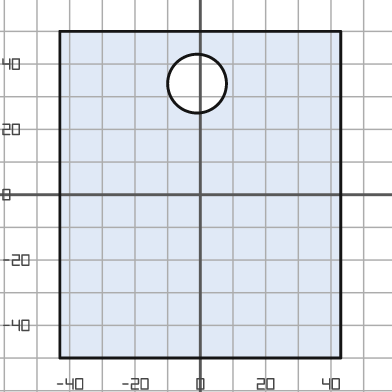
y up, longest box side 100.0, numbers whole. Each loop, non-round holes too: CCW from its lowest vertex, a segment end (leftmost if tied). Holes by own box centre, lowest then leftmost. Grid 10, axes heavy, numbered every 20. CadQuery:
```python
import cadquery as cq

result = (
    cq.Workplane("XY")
    .moveTo(-43.0, -50.0)
    .lineTo(43.0, -50.0)
    .lineTo(43.0, 50.0)
    .lineTo(-43.0, 50.0)
    .close()
    .moveTo(-1.0, 34.0)
    .circle(9.0)
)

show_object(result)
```